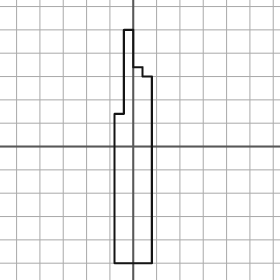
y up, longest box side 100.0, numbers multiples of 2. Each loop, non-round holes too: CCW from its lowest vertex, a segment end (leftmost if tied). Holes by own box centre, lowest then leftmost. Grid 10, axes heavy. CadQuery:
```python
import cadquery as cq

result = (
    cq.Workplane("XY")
    .moveTo(-8.0, -50.0)
    .lineTo(8.0, -50.0)
    .lineTo(8.0, 30.0)
    .lineTo(4.0, 30.0)
    .lineTo(4.0, 34.0)
    .lineTo(0.0, 34.0)
    .lineTo(0.0, 50.0)
    .lineTo(-4.0, 50.0)
    .lineTo(-4.0, 14.0)
    .lineTo(-8.0, 14.0)
    .close()
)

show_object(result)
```